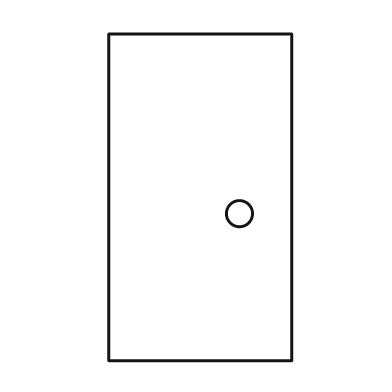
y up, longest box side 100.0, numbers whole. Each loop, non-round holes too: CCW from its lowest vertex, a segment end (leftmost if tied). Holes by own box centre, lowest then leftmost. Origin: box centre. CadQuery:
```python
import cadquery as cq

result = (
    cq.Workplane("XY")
    .moveTo(-28.0, -50.0)
    .lineTo(28.0, -50.0)
    .lineTo(28.0, 50.0)
    .lineTo(-28.0, 50.0)
    .close()
    .moveTo(12.0, -5.0)
    .circle(4.0)
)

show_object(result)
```